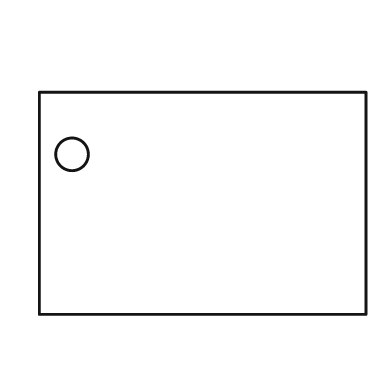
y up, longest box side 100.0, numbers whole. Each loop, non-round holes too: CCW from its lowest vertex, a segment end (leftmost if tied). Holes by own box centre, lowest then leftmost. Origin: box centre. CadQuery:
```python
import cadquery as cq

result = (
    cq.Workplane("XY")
    .moveTo(-50.0, -34.0)
    .lineTo(50.0, -34.0)
    .lineTo(50.0, 34.0)
    .lineTo(-50.0, 34.0)
    .close()
    .moveTo(-40.0, 15.0)
    .circle(5.0)
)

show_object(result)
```